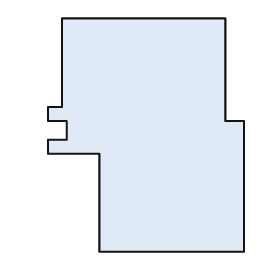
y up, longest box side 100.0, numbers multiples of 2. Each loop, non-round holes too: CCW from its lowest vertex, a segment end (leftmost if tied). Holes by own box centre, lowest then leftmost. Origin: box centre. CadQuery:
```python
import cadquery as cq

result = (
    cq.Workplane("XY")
    .moveTo(-20.0, -50.0)
    .lineTo(42.0, -50.0)
    .lineTo(42.0, 6.0)
    .lineTo(34.0, 6.0)
    .lineTo(34.0, 50.0)
    .lineTo(-36.0, 50.0)
    .lineTo(-36.0, 12.0)
    .lineTo(-42.0, 12.0)
    .lineTo(-42.0, 6.0)
    .lineTo(-34.0, 6.0)
    .lineTo(-34.0, -2.0)
    .lineTo(-42.0, -2.0)
    .lineTo(-42.0, -8.0)
    .lineTo(-20.0, -8.0)
    .close()
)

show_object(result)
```